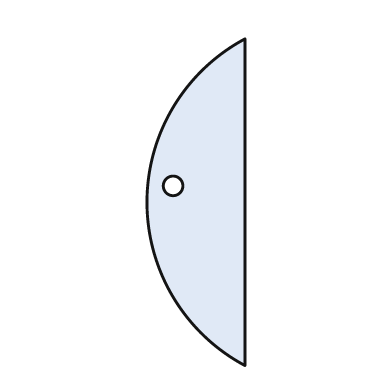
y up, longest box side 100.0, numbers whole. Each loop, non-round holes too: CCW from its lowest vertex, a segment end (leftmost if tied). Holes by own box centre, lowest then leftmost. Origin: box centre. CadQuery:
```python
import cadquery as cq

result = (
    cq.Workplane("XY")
    .moveTo(15.0, -50.0)
    .lineTo(15.0, 50.0)
    .threePointArc((-15.0, 0.0), (15.0, -50.0))
    .close()
    .moveTo(-7.0, 5.0)
    .circle(3.0)
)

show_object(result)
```